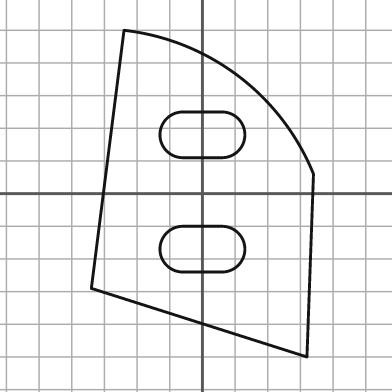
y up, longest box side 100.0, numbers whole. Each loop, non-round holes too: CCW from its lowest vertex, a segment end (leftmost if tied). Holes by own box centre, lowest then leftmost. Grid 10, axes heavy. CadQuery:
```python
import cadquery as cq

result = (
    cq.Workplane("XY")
    .moveTo(32.0, -50.0)
    .lineTo(34.0, 6.0)
    .threePointArc((11.0, 36.0), (-24.0, 50.0))
    .lineTo(-34.0, -29.0)
    .close()
    .moveTo(-6.0, -24.0)
    .lineTo(6.0, -24.0)
    .threePointArc((13.0, -17.0), (6.0, -10.0))
    .lineTo(-6.0, -10.0)
    .threePointArc((-13.0, -17.0), (-6.0, -24.0))
    .close()
    .moveTo(-6.0, 11.0)
    .lineTo(6.0, 11.0)
    .threePointArc((13.0, 18.0), (6.0, 25.0))
    .lineTo(-6.0, 25.0)
    .threePointArc((-13.0, 18.0), (-6.0, 11.0))
    .close()
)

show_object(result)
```